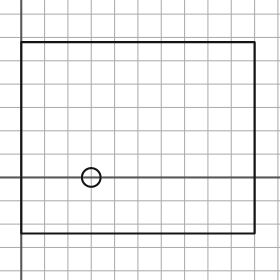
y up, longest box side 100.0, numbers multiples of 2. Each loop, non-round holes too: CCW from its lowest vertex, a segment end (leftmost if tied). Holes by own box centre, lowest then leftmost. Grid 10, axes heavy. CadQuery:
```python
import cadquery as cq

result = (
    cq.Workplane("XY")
    .moveTo(0.0, -24.0)
    .lineTo(100.0, -24.0)
    .lineTo(100.0, 58.0)
    .lineTo(0.0, 58.0)
    .close()
    .moveTo(30.0, 0.0)
    .circle(4.0)
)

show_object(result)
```